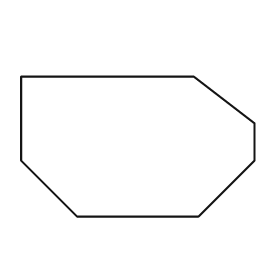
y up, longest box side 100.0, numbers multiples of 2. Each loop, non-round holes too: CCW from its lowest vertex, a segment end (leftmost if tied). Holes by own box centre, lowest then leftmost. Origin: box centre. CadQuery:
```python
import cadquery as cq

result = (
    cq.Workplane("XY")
    .moveTo(-26.0, -30.0)
    .lineTo(26.0, -30.0)
    .lineTo(50.0, -6.0)
    .lineTo(50.0, 10.0)
    .lineTo(24.0, 30.0)
    .lineTo(-50.0, 30.0)
    .lineTo(-50.0, -6.0)
    .close()
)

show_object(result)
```